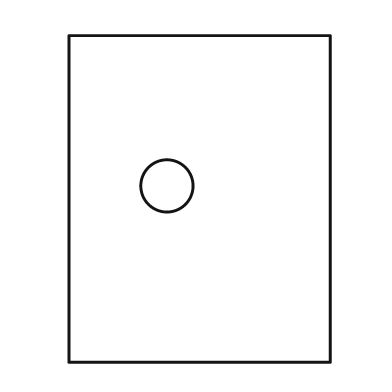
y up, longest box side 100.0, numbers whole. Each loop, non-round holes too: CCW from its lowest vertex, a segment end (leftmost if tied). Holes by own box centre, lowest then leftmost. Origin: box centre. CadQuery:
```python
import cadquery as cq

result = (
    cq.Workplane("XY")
    .moveTo(-40.0, -50.0)
    .lineTo(40.0, -50.0)
    .lineTo(40.0, 50.0)
    .lineTo(-40.0, 50.0)
    .close()
    .moveTo(-10.0, 4.0)
    .circle(8.0)
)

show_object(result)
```